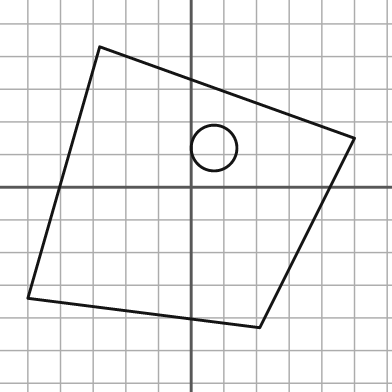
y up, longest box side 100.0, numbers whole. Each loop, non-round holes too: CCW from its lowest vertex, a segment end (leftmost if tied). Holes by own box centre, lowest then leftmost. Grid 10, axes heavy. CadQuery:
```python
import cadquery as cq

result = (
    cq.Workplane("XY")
    .moveTo(21.0, -43.0)
    .lineTo(50.0, 15.0)
    .lineTo(-28.0, 43.0)
    .lineTo(-50.0, -34.0)
    .close()
    .moveTo(7.0, 12.0)
    .circle(7.0)
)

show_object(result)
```